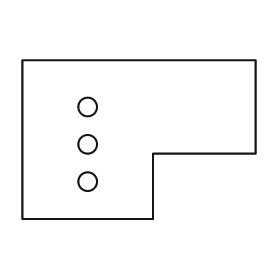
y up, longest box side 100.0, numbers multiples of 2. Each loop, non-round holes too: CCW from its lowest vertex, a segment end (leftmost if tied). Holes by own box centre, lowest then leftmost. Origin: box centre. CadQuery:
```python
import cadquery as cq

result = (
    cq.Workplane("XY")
    .moveTo(-50.0, -34.0)
    .lineTo(6.0, -34.0)
    .lineTo(6.0, -6.0)
    .lineTo(50.0, -6.0)
    .lineTo(50.0, 34.0)
    .lineTo(-50.0, 34.0)
    .close()
    .moveTo(-22.0, -18.0)
    .circle(4.0)
    .moveTo(-22.0, -2.0)
    .circle(4.0)
    .moveTo(-22.0, 14.0)
    .circle(4.0)
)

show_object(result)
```